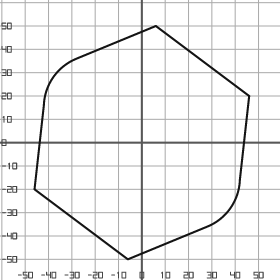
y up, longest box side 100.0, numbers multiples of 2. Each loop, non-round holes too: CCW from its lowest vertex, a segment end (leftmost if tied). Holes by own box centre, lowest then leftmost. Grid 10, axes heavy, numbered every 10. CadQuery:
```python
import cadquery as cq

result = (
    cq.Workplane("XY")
    .moveTo(-6.0, -50.0)
    .lineTo(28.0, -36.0)
    .threePointArc((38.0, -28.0), (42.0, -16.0))
    .lineTo(46.0, 20.0)
    .lineTo(6.0, 50.0)
    .lineTo(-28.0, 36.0)
    .threePointArc((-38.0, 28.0), (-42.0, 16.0))
    .lineTo(-46.0, -20.0)
    .close()
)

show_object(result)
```